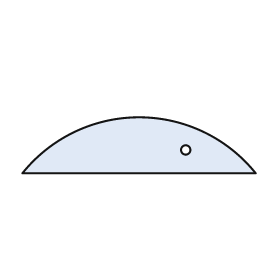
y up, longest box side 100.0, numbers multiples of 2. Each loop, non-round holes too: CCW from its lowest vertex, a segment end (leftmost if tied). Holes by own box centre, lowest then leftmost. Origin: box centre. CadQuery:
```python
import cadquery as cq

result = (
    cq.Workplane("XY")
    .moveTo(-50.0, -12.0)
    .lineTo(50.0, -12.0)
    .threePointArc((0.0, 12.0), (-50.0, -12.0))
    .close()
    .moveTo(20.0, -2.0)
    .circle(2.0)
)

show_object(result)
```